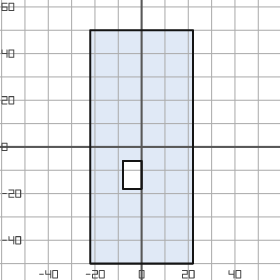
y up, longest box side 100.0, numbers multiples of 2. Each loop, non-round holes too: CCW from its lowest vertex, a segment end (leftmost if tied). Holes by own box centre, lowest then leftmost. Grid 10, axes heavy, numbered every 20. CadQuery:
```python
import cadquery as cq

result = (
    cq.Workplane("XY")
    .moveTo(-22.0, -50.0)
    .lineTo(22.0, -50.0)
    .lineTo(22.0, 50.0)
    .lineTo(-22.0, 50.0)
    .close()
    .moveTo(-8.0, -18.0)
    .lineTo(0.0, -18.0)
    .lineTo(0.0, -6.0)
    .lineTo(-8.0, -6.0)
    .close()
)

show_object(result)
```